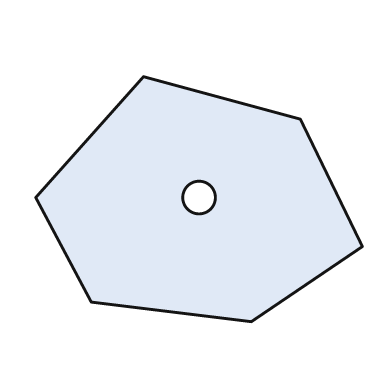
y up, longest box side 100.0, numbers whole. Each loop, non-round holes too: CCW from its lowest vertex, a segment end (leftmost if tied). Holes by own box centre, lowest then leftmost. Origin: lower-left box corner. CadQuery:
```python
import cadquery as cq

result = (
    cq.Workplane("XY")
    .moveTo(66.0, 0.0)
    .lineTo(100.0, 23.0)
    .lineTo(81.0, 62.0)
    .lineTo(33.0, 75.0)
    .lineTo(0.0, 38.0)
    .lineTo(17.0, 6.0)
    .close()
    .moveTo(50.0, 38.0)
    .circle(5.0)
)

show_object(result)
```